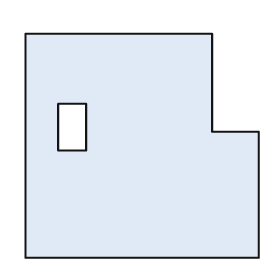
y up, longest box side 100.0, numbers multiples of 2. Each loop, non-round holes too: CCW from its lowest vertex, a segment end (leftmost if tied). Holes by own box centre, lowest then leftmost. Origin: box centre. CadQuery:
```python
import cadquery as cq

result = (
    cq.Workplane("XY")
    .moveTo(-50.0, -48.0)
    .lineTo(50.0, -48.0)
    .lineTo(50.0, 6.0)
    .lineTo(30.0, 6.0)
    .lineTo(30.0, 48.0)
    .lineTo(-50.0, 48.0)
    .close()
    .moveTo(-36.0, -2.0)
    .lineTo(-24.0, -2.0)
    .lineTo(-24.0, 18.0)
    .lineTo(-36.0, 18.0)
    .close()
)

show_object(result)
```